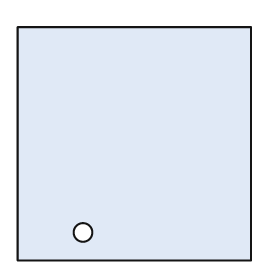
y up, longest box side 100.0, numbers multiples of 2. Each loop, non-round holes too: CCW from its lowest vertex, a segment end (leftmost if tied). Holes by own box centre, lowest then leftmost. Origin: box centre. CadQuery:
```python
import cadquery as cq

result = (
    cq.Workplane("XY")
    .moveTo(-50.0, -50.0)
    .lineTo(50.0, -50.0)
    .lineTo(50.0, 50.0)
    .lineTo(-50.0, 50.0)
    .close()
    .moveTo(-22.0, -38.0)
    .circle(4.0)
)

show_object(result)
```